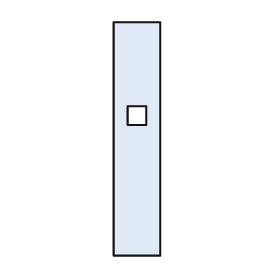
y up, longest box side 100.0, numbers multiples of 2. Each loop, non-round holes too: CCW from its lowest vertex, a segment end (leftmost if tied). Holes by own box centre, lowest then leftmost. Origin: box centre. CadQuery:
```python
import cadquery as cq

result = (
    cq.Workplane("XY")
    .moveTo(-10.0, -50.0)
    .lineTo(10.0, -50.0)
    .lineTo(10.0, 50.0)
    .lineTo(-10.0, 50.0)
    .close()
    .moveTo(-4.0, 6.0)
    .lineTo(4.0, 6.0)
    .lineTo(4.0, 14.0)
    .lineTo(-4.0, 14.0)
    .close()
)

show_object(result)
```